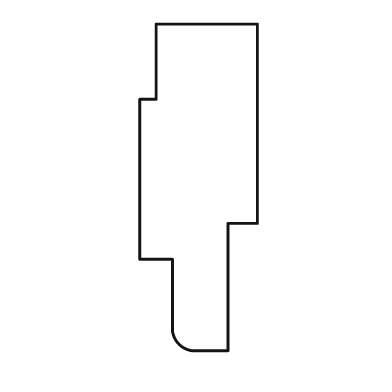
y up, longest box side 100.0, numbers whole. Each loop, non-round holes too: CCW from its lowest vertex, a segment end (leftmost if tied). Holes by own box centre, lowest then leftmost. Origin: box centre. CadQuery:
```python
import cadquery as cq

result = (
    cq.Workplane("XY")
    .moveTo(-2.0, -50.0)
    .lineTo(9.0, -50.0)
    .lineTo(9.0, -11.0)
    .lineTo(18.0, -11.0)
    .lineTo(18.0, 50.0)
    .lineTo(-13.0, 50.0)
    .lineTo(-13.0, 27.0)
    .lineTo(-18.0, 27.0)
    .lineTo(-18.0, -22.0)
    .lineTo(-8.0, -22.0)
    .lineTo(-8.0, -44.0)
    .threePointArc((-6.0, -48.0), (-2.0, -50.0))
    .close()
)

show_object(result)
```